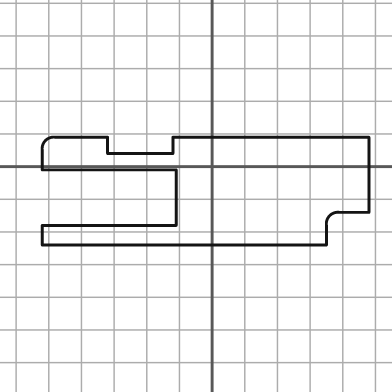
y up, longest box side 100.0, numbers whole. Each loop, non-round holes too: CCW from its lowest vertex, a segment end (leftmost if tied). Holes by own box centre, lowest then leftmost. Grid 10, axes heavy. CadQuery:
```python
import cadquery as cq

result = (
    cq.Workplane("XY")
    .moveTo(-52.0, -24.0)
    .lineTo(35.0, -24.0)
    .lineTo(35.0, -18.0)
    .threePointArc((36.0, -15.0), (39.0, -14.0))
    .lineTo(48.0, -14.0)
    .lineTo(48.0, 9.0)
    .lineTo(-12.0, 9.0)
    .lineTo(-12.0, 4.0)
    .lineTo(-32.0, 4.0)
    .lineTo(-32.0, 9.0)
    .lineTo(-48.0, 9.0)
    .threePointArc((-51.0, 8.0), (-52.0, 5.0))
    .lineTo(-52.0, -1.0)
    .lineTo(-11.0, -1.0)
    .lineTo(-11.0, -18.0)
    .lineTo(-52.0, -18.0)
    .close()
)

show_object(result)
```